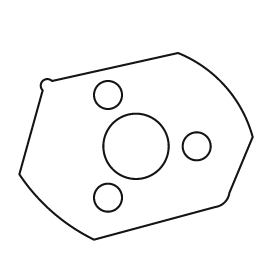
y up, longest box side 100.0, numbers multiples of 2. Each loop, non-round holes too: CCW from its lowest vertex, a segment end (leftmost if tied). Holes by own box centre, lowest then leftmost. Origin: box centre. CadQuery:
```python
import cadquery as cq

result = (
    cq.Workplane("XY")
    .moveTo(-18.0, -40.0)
    .lineTo(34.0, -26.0)
    .threePointArc((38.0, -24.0), (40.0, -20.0))
    .lineTo(50.0, 4.0)
    .threePointArc((38.0, 26.0), (18.0, 40.0))
    .lineTo(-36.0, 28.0)
    .threePointArc((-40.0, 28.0), (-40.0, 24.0))
    .lineTo(-50.0, -12.0)
    .threePointArc((-36.0, -28.0), (-18.0, -40.0))
    .close()
    .moveTo(-12.0, -22.0)
    .circle(6.0)
    .moveTo(0.0, 0.0)
    .circle(14.0)
    .moveTo(26.0, 0.0)
    .circle(6.0)
    .moveTo(-12.0, 22.0)
    .circle(6.0)
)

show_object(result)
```